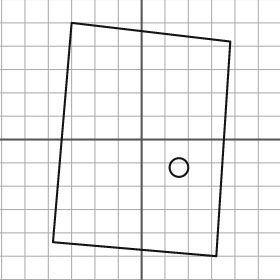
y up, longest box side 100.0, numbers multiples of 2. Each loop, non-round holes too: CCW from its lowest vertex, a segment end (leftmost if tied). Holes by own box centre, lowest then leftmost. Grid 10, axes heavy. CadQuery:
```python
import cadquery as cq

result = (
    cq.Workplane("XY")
    .moveTo(32.0, -50.0)
    .lineTo(38.0, 42.0)
    .lineTo(-30.0, 50.0)
    .lineTo(-38.0, -44.0)
    .close()
    .moveTo(16.0, -12.0)
    .circle(4.0)
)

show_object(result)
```